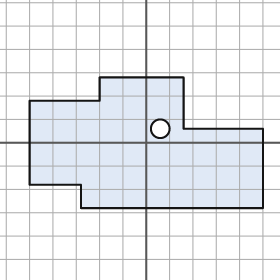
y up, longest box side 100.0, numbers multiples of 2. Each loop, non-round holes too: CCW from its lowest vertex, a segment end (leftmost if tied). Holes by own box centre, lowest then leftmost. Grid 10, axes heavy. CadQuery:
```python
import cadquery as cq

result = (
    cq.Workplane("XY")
    .moveTo(-28.0, -28.0)
    .lineTo(50.0, -28.0)
    .lineTo(50.0, 6.0)
    .lineTo(16.0, 6.0)
    .lineTo(16.0, 28.0)
    .lineTo(-20.0, 28.0)
    .lineTo(-20.0, 18.0)
    .lineTo(-50.0, 18.0)
    .lineTo(-50.0, -18.0)
    .lineTo(-28.0, -18.0)
    .close()
    .moveTo(6.0, 6.0)
    .circle(4.0)
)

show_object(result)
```